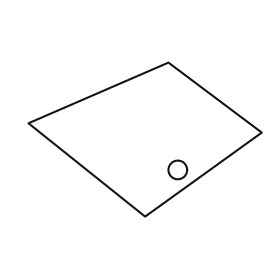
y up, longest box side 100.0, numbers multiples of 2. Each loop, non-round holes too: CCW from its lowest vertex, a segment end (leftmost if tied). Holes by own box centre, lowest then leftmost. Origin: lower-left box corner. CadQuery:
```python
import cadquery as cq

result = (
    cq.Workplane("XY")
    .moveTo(50.0, 0.0)
    .lineTo(100.0, 36.0)
    .lineTo(60.0, 66.0)
    .lineTo(0.0, 40.0)
    .close()
    .moveTo(64.0, 20.0)
    .circle(4.0)
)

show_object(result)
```